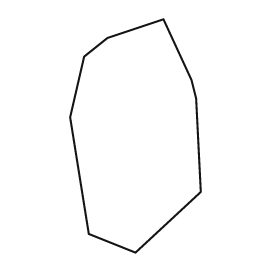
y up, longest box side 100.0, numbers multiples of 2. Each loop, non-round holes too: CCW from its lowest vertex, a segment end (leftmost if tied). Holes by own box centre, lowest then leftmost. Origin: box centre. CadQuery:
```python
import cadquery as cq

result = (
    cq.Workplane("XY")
    .moveTo(0.0, -50.0)
    .lineTo(28.0, -24.0)
    .lineTo(26.0, 16.0)
    .lineTo(24.0, 24.0)
    .lineTo(12.0, 50.0)
    .lineTo(-12.0, 42.0)
    .lineTo(-22.0, 34.0)
    .lineTo(-28.0, 8.0)
    .lineTo(-20.0, -42.0)
    .close()
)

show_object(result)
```